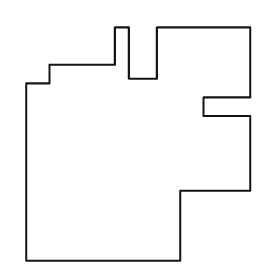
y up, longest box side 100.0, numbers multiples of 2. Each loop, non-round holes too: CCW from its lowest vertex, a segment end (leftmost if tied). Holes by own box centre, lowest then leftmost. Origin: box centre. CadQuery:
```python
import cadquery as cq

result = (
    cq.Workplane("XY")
    .moveTo(-48.0, -50.0)
    .lineTo(18.0, -50.0)
    .lineTo(18.0, -20.0)
    .lineTo(48.0, -20.0)
    .lineTo(48.0, 12.0)
    .lineTo(28.0, 12.0)
    .lineTo(28.0, 20.0)
    .lineTo(48.0, 20.0)
    .lineTo(48.0, 50.0)
    .lineTo(8.0, 50.0)
    .lineTo(8.0, 28.0)
    .lineTo(-4.0, 28.0)
    .lineTo(-4.0, 50.0)
    .lineTo(-10.0, 50.0)
    .lineTo(-10.0, 34.0)
    .lineTo(-38.0, 34.0)
    .lineTo(-38.0, 26.0)
    .lineTo(-48.0, 26.0)
    .close()
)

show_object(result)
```